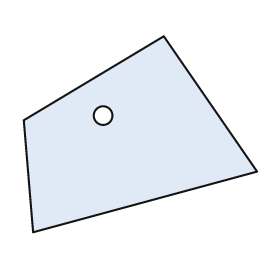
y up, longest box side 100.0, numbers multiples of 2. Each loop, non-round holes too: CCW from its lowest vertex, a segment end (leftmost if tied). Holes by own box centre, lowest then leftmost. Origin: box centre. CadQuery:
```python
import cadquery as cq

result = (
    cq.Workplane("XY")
    .moveTo(-46.0, -42.0)
    .lineTo(50.0, -16.0)
    .lineTo(10.0, 42.0)
    .lineTo(-50.0, 6.0)
    .close()
    .moveTo(-16.0, 8.0)
    .circle(4.0)
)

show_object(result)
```